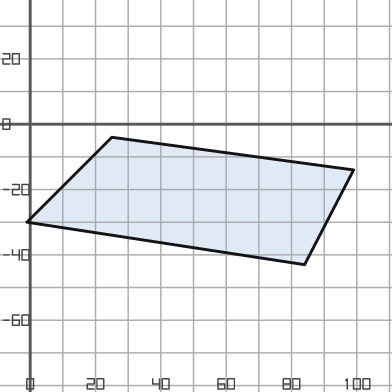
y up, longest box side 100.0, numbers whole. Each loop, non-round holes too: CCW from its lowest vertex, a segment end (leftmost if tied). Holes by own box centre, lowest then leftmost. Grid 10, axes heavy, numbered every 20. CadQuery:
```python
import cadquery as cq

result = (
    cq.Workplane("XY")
    .moveTo(84.0, -43.0)
    .lineTo(99.0, -14.0)
    .lineTo(25.0, -4.0)
    .lineTo(-1.0, -30.0)
    .close()
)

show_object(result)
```